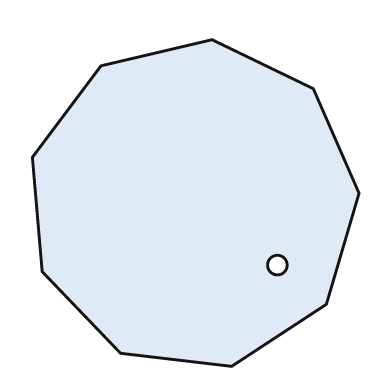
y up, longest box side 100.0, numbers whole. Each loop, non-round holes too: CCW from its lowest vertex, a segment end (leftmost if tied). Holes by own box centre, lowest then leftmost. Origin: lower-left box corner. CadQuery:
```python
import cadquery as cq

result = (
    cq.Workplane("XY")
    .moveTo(61.0, 0.0)
    .lineTo(90.0, 19.0)
    .lineTo(100.0, 53.0)
    .lineTo(86.0, 85.0)
    .lineTo(55.0, 100.0)
    .lineTo(21.0, 92.0)
    .lineTo(0.0, 64.0)
    .lineTo(3.0, 29.0)
    .lineTo(27.0, 4.0)
    .close()
    .moveTo(75.0, 31.0)
    .circle(3.0)
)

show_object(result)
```